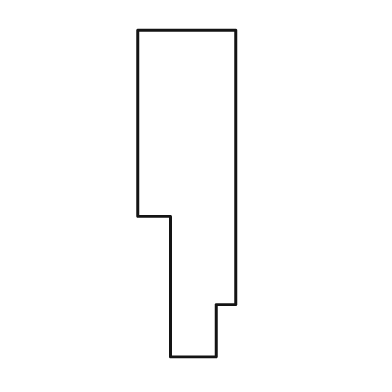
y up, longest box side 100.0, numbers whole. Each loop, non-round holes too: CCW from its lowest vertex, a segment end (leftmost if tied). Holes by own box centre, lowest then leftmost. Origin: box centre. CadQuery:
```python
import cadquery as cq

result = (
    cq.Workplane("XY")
    .moveTo(-5.0, -50.0)
    .lineTo(9.0, -50.0)
    .lineTo(9.0, -34.0)
    .lineTo(15.0, -34.0)
    .lineTo(15.0, 50.0)
    .lineTo(-15.0, 50.0)
    .lineTo(-15.0, -7.0)
    .lineTo(-5.0, -7.0)
    .close()
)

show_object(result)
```